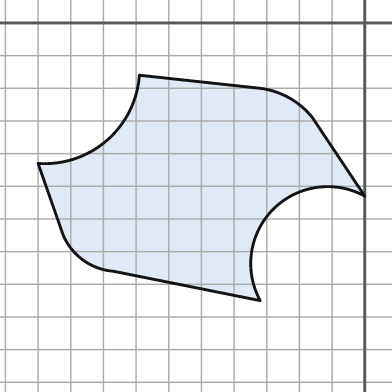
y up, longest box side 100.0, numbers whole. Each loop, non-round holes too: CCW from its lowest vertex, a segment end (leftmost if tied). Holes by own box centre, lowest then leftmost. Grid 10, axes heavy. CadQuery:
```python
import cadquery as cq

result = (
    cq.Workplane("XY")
    .moveTo(-32.0, -85.0)
    .threePointArc((-28.0, -57.0), (0.0, -53.0))
    .lineTo(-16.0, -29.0)
    .threePointArc((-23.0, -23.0), (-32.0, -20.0))
    .lineTo(-69.0, -16.0)
    .threePointArc((-79.0, -36.0), (-100.0, -43.0))
    .lineTo(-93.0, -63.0)
    .threePointArc((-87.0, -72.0), (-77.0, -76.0))
    .close()
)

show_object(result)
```